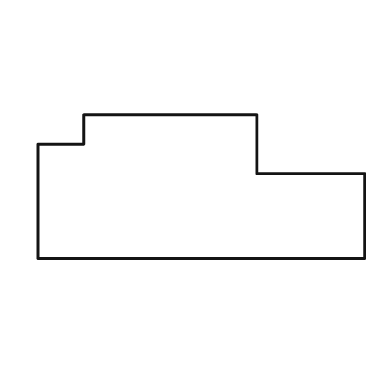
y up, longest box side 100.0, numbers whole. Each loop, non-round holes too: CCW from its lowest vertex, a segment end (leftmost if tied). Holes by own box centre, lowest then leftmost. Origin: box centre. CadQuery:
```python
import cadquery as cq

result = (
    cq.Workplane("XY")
    .moveTo(-50.0, -22.0)
    .lineTo(50.0, -22.0)
    .lineTo(50.0, 4.0)
    .lineTo(17.0, 4.0)
    .lineTo(17.0, 22.0)
    .lineTo(-36.0, 22.0)
    .lineTo(-36.0, 13.0)
    .lineTo(-50.0, 13.0)
    .close()
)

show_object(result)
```